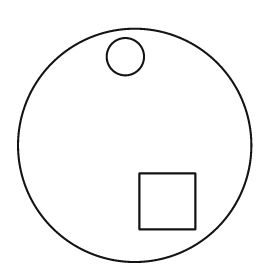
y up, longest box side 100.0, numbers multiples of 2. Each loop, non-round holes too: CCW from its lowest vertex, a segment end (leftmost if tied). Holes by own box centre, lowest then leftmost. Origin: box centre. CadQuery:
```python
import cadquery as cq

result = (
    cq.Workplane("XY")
    .moveTo(0.0, 0.0)
    .circle(50.0)
    .moveTo(2.0, -36.0)
    .lineTo(26.0, -36.0)
    .lineTo(26.0, -12.0)
    .lineTo(2.0, -12.0)
    .close()
    .moveTo(-4.0, 38.0)
    .circle(8.0)
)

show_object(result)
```